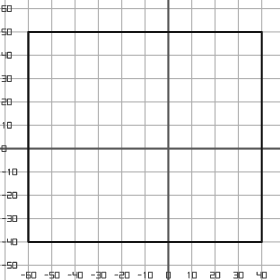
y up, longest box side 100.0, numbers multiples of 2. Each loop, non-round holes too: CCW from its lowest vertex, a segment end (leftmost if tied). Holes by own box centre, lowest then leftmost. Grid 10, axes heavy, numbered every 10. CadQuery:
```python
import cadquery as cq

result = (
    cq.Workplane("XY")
    .moveTo(-60.0, -40.0)
    .lineTo(40.0, -40.0)
    .lineTo(40.0, 50.0)
    .lineTo(-60.0, 50.0)
    .close()
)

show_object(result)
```